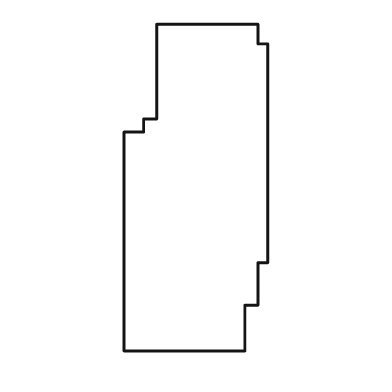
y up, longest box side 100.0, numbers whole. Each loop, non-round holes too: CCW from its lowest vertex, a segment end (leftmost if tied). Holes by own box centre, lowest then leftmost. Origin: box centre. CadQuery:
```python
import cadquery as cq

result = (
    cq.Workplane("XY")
    .moveTo(-22.0, -50.0)
    .lineTo(15.0, -50.0)
    .lineTo(15.0, -36.0)
    .lineTo(19.0, -36.0)
    .lineTo(19.0, -23.0)
    .lineTo(22.0, -23.0)
    .lineTo(22.0, 44.0)
    .lineTo(19.0, 44.0)
    .lineTo(19.0, 50.0)
    .lineTo(-12.0, 50.0)
    .lineTo(-12.0, 21.0)
    .lineTo(-16.0, 21.0)
    .lineTo(-16.0, 17.0)
    .lineTo(-22.0, 17.0)
    .close()
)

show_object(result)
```